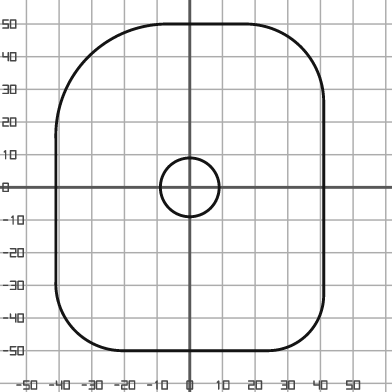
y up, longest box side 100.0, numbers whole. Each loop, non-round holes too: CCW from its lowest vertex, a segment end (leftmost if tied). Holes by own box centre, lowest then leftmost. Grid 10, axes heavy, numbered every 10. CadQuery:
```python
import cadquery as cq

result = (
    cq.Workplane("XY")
    .moveTo(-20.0, -50.0)
    .lineTo(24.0, -50.0)
    .threePointArc((36.0, -45.0), (41.0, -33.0))
    .lineTo(41.0, 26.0)
    .threePointArc((34.0, 43.0), (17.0, 50.0))
    .lineTo(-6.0, 50.0)
    .threePointArc((-31.0, 40.0), (-41.0, 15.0))
    .lineTo(-41.0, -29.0)
    .threePointArc((-35.0, -44.0), (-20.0, -50.0))
    .close()
    .moveTo(0.0, 0.0)
    .circle(9.0)
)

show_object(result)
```